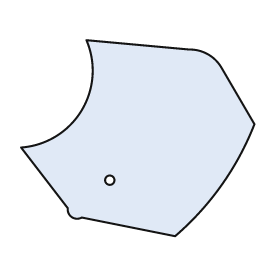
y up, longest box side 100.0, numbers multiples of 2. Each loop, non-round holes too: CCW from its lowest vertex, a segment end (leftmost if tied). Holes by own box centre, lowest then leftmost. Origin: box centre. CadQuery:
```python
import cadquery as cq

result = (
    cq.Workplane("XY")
    .moveTo(16.0, -42.0)
    .threePointArc((36.0, -20.0), (50.0, 6.0))
    .lineTo(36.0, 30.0)
    .threePointArc((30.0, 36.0), (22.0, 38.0))
    .lineTo(-22.0, 42.0)
    .threePointArc((-24.0, 12.0), (-50.0, -4.0))
    .lineTo(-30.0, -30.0)
    .threePointArc((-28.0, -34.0), (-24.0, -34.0))
    .close()
    .moveTo(-12.0, -18.0)
    .circle(2.0)
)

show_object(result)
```